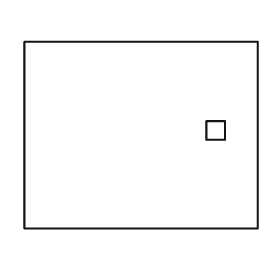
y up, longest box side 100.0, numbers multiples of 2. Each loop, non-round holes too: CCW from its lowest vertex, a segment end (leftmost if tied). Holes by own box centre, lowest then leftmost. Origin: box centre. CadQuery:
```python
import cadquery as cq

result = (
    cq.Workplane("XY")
    .moveTo(-50.0, -40.0)
    .lineTo(50.0, -40.0)
    .lineTo(50.0, 40.0)
    .lineTo(-50.0, 40.0)
    .close()
    .moveTo(28.0, -2.0)
    .lineTo(36.0, -2.0)
    .lineTo(36.0, 6.0)
    .lineTo(28.0, 6.0)
    .close()
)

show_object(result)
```